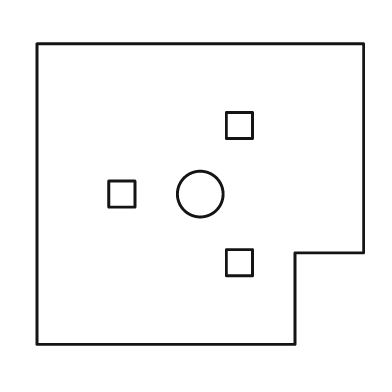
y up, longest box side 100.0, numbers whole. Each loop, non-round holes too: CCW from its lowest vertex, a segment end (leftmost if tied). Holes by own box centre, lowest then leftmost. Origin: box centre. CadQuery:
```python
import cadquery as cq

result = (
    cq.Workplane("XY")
    .moveTo(-50.0, -46.0)
    .lineTo(29.0, -46.0)
    .lineTo(29.0, -18.0)
    .lineTo(50.0, -18.0)
    .lineTo(50.0, 46.0)
    .lineTo(-50.0, 46.0)
    .close()
    .moveTo(8.0, -25.0)
    .lineTo(16.0, -25.0)
    .lineTo(16.0, -17.0)
    .lineTo(8.0, -17.0)
    .close()
    .moveTo(-28.0, -4.0)
    .lineTo(-20.0, -4.0)
    .lineTo(-20.0, 4.0)
    .lineTo(-28.0, 4.0)
    .close()
    .moveTo(0.0, 0.0)
    .circle(7.0)
    .moveTo(8.0, 17.0)
    .lineTo(16.0, 17.0)
    .lineTo(16.0, 25.0)
    .lineTo(8.0, 25.0)
    .close()
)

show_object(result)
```